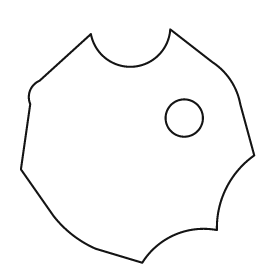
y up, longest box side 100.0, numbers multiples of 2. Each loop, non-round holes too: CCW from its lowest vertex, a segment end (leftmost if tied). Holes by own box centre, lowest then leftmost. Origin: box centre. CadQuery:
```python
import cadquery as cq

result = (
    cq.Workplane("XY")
    .moveTo(2.0, -50.0)
    .threePointArc((16.0, -38.0), (34.0, -36.0))
    .threePointArc((38.0, -18.0), (50.0, -4.0))
    .lineTo(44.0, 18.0)
    .threePointArc((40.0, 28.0), (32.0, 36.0))
    .lineTo(14.0, 50.0)
    .threePointArc((-2.0, 34.0), (-20.0, 48.0))
    .lineTo(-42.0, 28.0)
    .threePointArc((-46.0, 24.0), (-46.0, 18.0))
    .lineTo(-50.0, -10.0)
    .lineTo(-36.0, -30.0)
    .threePointArc((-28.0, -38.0), (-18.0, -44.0))
    .close()
    .moveTo(20.0, 12.0)
    .circle(8.0)
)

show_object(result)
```